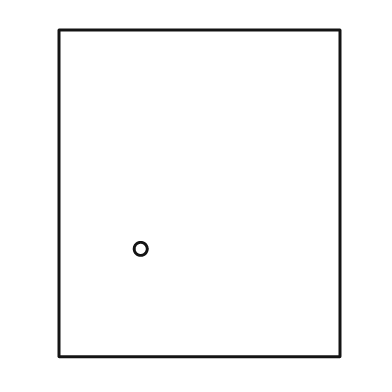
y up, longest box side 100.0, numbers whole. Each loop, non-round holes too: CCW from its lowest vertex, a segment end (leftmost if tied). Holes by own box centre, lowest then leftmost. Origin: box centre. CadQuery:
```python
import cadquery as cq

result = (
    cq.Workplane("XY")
    .moveTo(-43.0, -50.0)
    .lineTo(43.0, -50.0)
    .lineTo(43.0, 50.0)
    .lineTo(-43.0, 50.0)
    .close()
    .moveTo(-18.0, -17.0)
    .circle(2.0)
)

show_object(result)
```